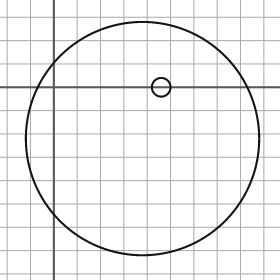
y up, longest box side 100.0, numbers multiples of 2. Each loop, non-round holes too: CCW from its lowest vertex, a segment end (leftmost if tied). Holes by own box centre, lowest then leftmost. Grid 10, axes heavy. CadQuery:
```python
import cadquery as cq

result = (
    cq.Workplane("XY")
    .moveTo(38.0, -22.0)
    .circle(50.0)
    .moveTo(46.0, 0.0)
    .circle(4.0)
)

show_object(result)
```